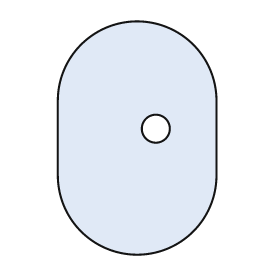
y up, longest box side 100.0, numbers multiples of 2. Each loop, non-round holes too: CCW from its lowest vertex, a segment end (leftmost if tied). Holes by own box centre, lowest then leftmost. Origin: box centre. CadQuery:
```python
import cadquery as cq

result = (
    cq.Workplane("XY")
    .moveTo(-34.0, -16.0)
    .threePointArc((0.0, -50.0), (34.0, -16.0))
    .lineTo(34.0, 16.0)
    .threePointArc((0.0, 50.0), (-34.0, 16.0))
    .close()
    .moveTo(8.0, 4.0)
    .circle(6.0)
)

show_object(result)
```